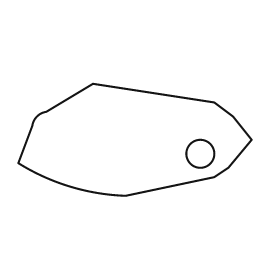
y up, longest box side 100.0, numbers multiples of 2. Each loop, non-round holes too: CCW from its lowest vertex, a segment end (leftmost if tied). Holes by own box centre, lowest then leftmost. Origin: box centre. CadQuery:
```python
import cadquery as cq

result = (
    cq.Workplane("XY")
    .moveTo(-4.0, -24.0)
    .lineTo(34.0, -16.0)
    .lineTo(40.0, -12.0)
    .lineTo(50.0, 0.0)
    .lineTo(42.0, 10.0)
    .lineTo(34.0, 16.0)
    .lineTo(-18.0, 24.0)
    .lineTo(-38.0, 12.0)
    .threePointArc((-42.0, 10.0), (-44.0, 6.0))
    .lineTo(-50.0, -10.0)
    .threePointArc((-28.0, -20.0), (-4.0, -24.0))
    .close()
    .moveTo(28.0, -6.0)
    .circle(6.0)
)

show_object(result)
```